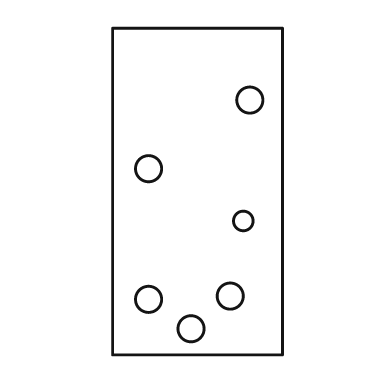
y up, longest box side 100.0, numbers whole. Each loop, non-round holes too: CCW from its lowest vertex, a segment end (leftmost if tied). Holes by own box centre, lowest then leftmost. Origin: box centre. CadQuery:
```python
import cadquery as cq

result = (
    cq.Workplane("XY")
    .moveTo(-26.0, -50.0)
    .lineTo(26.0, -50.0)
    .lineTo(26.0, 50.0)
    .lineTo(-26.0, 50.0)
    .close()
    .moveTo(-2.0, -42.0)
    .circle(4.0)
    .moveTo(-15.0, -33.0)
    .circle(4.0)
    .moveTo(10.0, -32.0)
    .circle(4.0)
    .moveTo(14.0, -9.0)
    .circle(3.0)
    .moveTo(-15.0, 7.0)
    .circle(4.0)
    .moveTo(16.0, 28.0)
    .circle(4.0)
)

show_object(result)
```